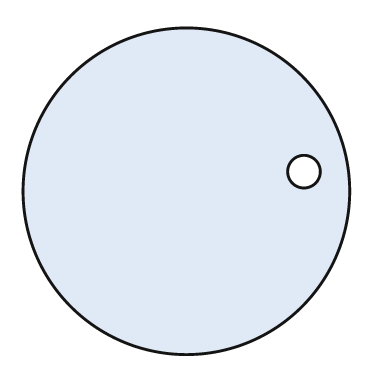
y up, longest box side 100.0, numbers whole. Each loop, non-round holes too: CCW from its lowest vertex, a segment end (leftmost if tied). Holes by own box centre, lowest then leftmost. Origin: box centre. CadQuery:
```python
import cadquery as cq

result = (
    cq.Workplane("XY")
    .moveTo(0.0, 0.0)
    .circle(50.0)
    .moveTo(36.0, 6.0)
    .circle(5.0)
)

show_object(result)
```